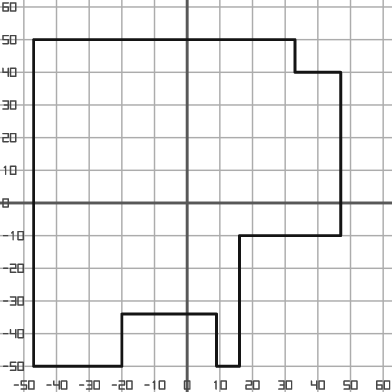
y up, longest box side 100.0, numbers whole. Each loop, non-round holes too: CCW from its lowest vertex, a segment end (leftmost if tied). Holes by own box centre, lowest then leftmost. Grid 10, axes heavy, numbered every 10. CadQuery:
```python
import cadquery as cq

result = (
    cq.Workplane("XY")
    .moveTo(-47.0, -50.0)
    .lineTo(-20.0, -50.0)
    .lineTo(-20.0, -34.0)
    .lineTo(9.0, -34.0)
    .lineTo(9.0, -50.0)
    .lineTo(16.0, -50.0)
    .lineTo(16.0, -10.0)
    .lineTo(47.0, -10.0)
    .lineTo(47.0, 40.0)
    .lineTo(33.0, 40.0)
    .lineTo(33.0, 50.0)
    .lineTo(-47.0, 50.0)
    .close()
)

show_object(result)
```